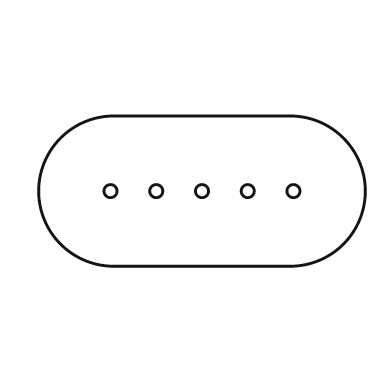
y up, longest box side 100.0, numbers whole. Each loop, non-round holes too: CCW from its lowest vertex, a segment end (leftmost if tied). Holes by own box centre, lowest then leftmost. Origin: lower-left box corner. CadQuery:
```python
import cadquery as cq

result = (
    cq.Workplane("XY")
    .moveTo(23.0, 0.0)
    .lineTo(77.0, 0.0)
    .threePointArc((100.0, 23.0), (77.0, 46.0))
    .lineTo(23.0, 46.0)
    .threePointArc((0.0, 23.0), (23.0, 0.0))
    .close()
    .moveTo(22.0, 23.0)
    .circle(2.0)
    .moveTo(36.0, 23.0)
    .circle(2.0)
    .moveTo(50.0, 23.0)
    .circle(2.0)
    .moveTo(64.0, 23.0)
    .circle(2.0)
    .moveTo(78.0, 23.0)
    .circle(2.0)
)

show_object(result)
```